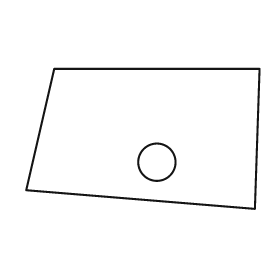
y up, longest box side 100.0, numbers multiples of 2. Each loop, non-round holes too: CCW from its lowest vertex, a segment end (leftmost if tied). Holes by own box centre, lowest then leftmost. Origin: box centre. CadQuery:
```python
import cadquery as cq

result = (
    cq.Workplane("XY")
    .moveTo(48.0, -30.0)
    .lineTo(50.0, 30.0)
    .lineTo(-38.0, 30.0)
    .lineTo(-50.0, -22.0)
    .close()
    .moveTo(6.0, -10.0)
    .circle(8.0)
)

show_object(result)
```